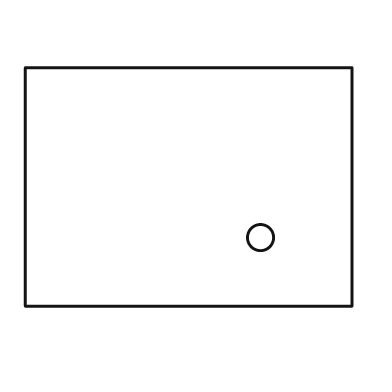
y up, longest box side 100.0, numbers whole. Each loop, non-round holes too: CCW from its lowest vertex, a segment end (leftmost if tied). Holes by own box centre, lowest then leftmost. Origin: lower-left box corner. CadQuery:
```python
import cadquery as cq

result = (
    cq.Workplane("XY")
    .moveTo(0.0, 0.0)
    .lineTo(100.0, 0.0)
    .lineTo(100.0, 73.0)
    .lineTo(0.0, 73.0)
    .close()
    .moveTo(72.0, 21.0)
    .circle(4.0)
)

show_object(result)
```